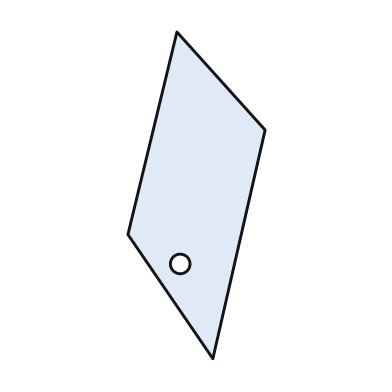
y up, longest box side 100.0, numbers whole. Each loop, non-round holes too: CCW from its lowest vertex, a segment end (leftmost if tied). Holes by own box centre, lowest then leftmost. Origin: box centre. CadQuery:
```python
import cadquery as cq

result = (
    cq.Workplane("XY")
    .moveTo(5.0, -50.0)
    .lineTo(21.0, 20.0)
    .lineTo(-6.0, 50.0)
    .lineTo(-21.0, -12.0)
    .close()
    .moveTo(-5.0, -21.0)
    .circle(3.0)
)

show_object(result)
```